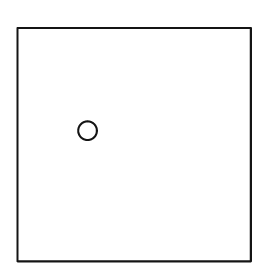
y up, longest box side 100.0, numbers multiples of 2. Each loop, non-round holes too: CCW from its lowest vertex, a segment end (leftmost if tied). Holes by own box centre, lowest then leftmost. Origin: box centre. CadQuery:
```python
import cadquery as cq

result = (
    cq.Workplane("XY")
    .moveTo(-50.0, -50.0)
    .lineTo(50.0, -50.0)
    .lineTo(50.0, 50.0)
    .lineTo(-50.0, 50.0)
    .close()
    .moveTo(-20.0, 6.0)
    .circle(4.0)
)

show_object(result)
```